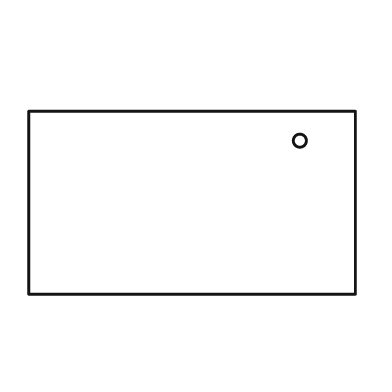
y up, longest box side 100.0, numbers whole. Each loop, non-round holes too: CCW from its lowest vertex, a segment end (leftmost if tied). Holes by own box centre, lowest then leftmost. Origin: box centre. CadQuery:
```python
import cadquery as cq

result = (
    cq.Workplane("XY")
    .moveTo(-50.0, -28.0)
    .lineTo(50.0, -28.0)
    .lineTo(50.0, 28.0)
    .lineTo(-50.0, 28.0)
    .close()
    .moveTo(33.0, 19.0)
    .circle(2.0)
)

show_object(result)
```